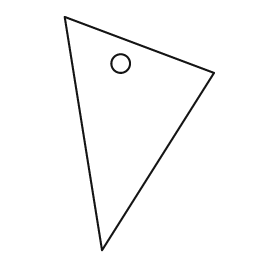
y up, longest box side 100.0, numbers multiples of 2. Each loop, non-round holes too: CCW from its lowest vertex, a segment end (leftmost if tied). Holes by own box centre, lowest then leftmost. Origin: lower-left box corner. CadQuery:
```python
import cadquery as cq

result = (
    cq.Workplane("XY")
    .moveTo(16.0, 0.0)
    .lineTo(64.0, 76.0)
    .lineTo(0.0, 100.0)
    .close()
    .moveTo(24.0, 80.0)
    .circle(4.0)
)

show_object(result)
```